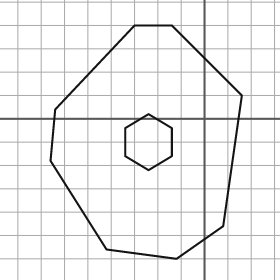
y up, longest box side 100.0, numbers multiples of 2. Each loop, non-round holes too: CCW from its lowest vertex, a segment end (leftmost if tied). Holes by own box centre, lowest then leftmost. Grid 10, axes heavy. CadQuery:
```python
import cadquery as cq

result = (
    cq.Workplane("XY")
    .moveTo(-12.0, -60.0)
    .lineTo(8.0, -46.0)
    .lineTo(16.0, 10.0)
    .lineTo(-14.0, 40.0)
    .lineTo(-30.0, 40.0)
    .lineTo(-64.0, 4.0)
    .lineTo(-66.0, -18.0)
    .lineTo(-42.0, -56.0)
    .close()
    .moveTo(-24.0, -22.0)
    .lineTo(-14.0, -16.0)
    .lineTo(-14.0, -4.0)
    .lineTo(-24.0, 2.0)
    .lineTo(-34.0, -4.0)
    .lineTo(-34.0, -16.0)
    .close()
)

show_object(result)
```